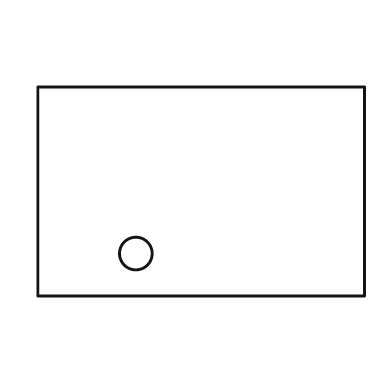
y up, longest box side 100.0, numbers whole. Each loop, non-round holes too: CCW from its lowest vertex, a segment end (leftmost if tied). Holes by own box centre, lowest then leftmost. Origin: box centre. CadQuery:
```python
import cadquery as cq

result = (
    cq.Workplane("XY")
    .moveTo(-50.0, -32.0)
    .lineTo(50.0, -32.0)
    .lineTo(50.0, 32.0)
    .lineTo(-50.0, 32.0)
    .close()
    .moveTo(-20.0, -19.0)
    .circle(5.0)
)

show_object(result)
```